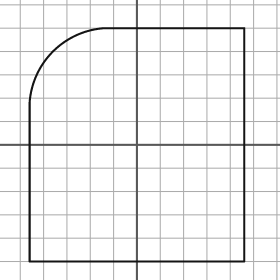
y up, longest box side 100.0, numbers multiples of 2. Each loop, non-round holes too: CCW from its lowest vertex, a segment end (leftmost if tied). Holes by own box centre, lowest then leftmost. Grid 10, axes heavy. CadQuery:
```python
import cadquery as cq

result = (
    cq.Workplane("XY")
    .moveTo(-46.0, -50.0)
    .lineTo(46.0, -50.0)
    .lineTo(46.0, 50.0)
    .lineTo(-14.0, 50.0)
    .threePointArc((-36.0, 40.0), (-46.0, 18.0))
    .close()
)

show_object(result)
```